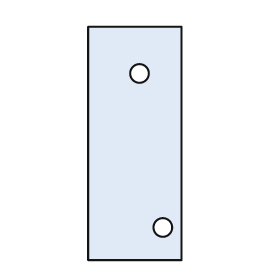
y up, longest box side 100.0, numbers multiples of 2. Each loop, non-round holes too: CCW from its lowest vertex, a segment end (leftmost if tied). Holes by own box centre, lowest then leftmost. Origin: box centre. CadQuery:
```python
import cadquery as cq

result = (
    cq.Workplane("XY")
    .moveTo(-20.0, -50.0)
    .lineTo(20.0, -50.0)
    .lineTo(20.0, 50.0)
    .lineTo(-20.0, 50.0)
    .close()
    .moveTo(12.0, -36.0)
    .circle(4.0)
    .moveTo(2.0, 30.0)
    .circle(4.0)
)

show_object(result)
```